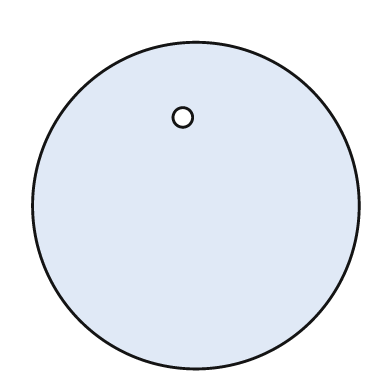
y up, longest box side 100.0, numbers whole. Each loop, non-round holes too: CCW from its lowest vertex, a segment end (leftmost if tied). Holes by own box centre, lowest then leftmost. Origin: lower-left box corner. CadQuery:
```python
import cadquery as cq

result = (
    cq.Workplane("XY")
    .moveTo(50.0, 50.0)
    .circle(50.0)
    .moveTo(46.0, 77.0)
    .circle(3.0)
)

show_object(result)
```